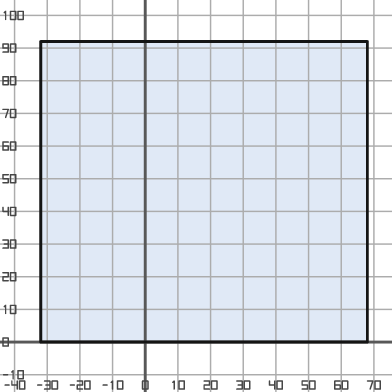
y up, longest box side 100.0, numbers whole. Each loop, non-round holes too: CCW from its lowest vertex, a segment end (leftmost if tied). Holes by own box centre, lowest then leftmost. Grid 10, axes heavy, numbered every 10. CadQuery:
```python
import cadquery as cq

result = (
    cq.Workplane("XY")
    .moveTo(-32.0, 0.0)
    .lineTo(68.0, 0.0)
    .lineTo(68.0, 92.0)
    .lineTo(-32.0, 92.0)
    .close()
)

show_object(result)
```